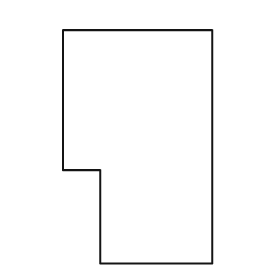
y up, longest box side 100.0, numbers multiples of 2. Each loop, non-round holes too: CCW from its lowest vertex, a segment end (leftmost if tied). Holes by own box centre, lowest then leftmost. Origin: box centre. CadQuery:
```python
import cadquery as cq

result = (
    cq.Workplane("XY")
    .moveTo(-16.0, -50.0)
    .lineTo(32.0, -50.0)
    .lineTo(32.0, 50.0)
    .lineTo(-32.0, 50.0)
    .lineTo(-32.0, -10.0)
    .lineTo(-16.0, -10.0)
    .close()
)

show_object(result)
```